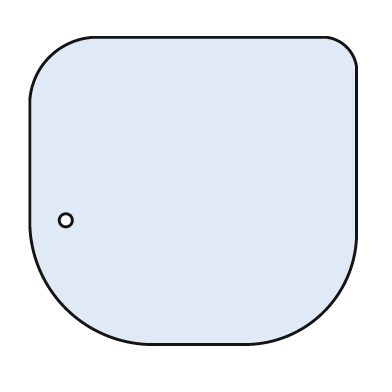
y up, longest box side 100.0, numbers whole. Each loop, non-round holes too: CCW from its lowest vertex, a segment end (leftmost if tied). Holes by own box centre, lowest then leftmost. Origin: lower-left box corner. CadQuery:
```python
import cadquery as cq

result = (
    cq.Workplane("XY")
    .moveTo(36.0, 0.0)
    .lineTo(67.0, 0.0)
    .threePointArc((90.0, 10.0), (100.0, 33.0))
    .lineTo(100.0, 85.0)
    .threePointArc((97.0, 91.0), (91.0, 94.0))
    .lineTo(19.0, 94.0)
    .threePointArc((6.0, 88.0), (0.0, 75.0))
    .lineTo(0.0, 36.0)
    .threePointArc((11.0, 11.0), (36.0, 0.0))
    .close()
    .moveTo(11.0, 38.0)
    .circle(2.0)
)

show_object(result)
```